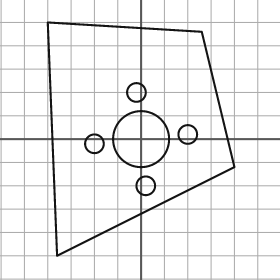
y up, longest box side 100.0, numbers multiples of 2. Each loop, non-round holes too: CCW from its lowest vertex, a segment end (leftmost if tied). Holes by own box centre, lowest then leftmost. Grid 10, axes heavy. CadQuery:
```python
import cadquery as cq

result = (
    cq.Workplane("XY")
    .moveTo(-36.0, -50.0)
    .lineTo(40.0, -12.0)
    .lineTo(26.0, 46.0)
    .lineTo(-40.0, 50.0)
    .close()
    .moveTo(2.0, -20.0)
    .circle(4.0)
    .moveTo(-20.0, -2.0)
    .circle(4.0)
    .moveTo(0.0, 0.0)
    .circle(12.0)
    .moveTo(20.0, 2.0)
    .circle(4.0)
    .moveTo(-2.0, 20.0)
    .circle(4.0)
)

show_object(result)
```